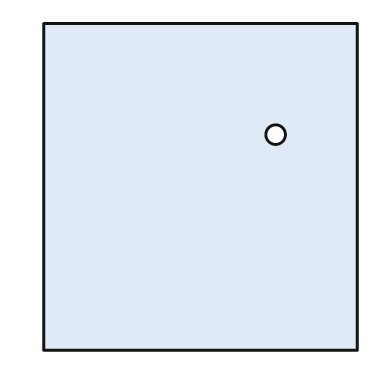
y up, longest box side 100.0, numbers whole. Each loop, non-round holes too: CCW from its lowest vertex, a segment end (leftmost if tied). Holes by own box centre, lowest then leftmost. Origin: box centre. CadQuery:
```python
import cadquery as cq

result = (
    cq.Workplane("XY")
    .moveTo(-48.0, -50.0)
    .lineTo(48.0, -50.0)
    .lineTo(48.0, 50.0)
    .lineTo(-48.0, 50.0)
    .close()
    .moveTo(23.0, 16.0)
    .circle(3.0)
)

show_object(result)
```